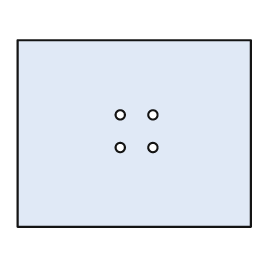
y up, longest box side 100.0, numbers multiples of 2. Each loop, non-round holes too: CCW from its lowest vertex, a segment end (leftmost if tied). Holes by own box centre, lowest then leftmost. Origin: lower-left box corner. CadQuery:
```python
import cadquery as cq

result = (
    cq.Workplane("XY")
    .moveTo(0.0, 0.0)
    .lineTo(100.0, 0.0)
    .lineTo(100.0, 80.0)
    .lineTo(0.0, 80.0)
    .close()
    .moveTo(44.0, 34.0)
    .circle(2.0)
    .moveTo(58.0, 34.0)
    .circle(2.0)
    .moveTo(44.0, 48.0)
    .circle(2.0)
    .moveTo(58.0, 48.0)
    .circle(2.0)
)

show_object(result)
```